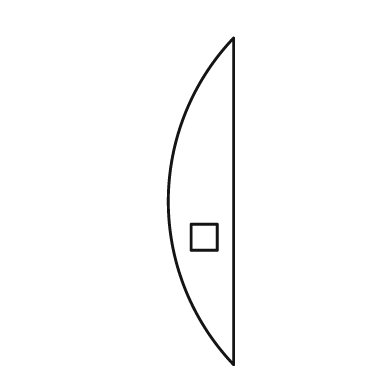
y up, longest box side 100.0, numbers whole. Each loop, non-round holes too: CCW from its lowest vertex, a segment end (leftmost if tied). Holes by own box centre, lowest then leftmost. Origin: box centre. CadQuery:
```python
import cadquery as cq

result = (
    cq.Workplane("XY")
    .moveTo(10.0, -50.0)
    .lineTo(10.0, 50.0)
    .threePointArc((-10.0, 0.0), (10.0, -50.0))
    .close()
    .moveTo(-3.0, -15.0)
    .lineTo(5.0, -15.0)
    .lineTo(5.0, -7.0)
    .lineTo(-3.0, -7.0)
    .close()
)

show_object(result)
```